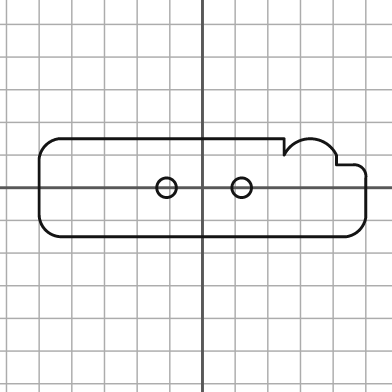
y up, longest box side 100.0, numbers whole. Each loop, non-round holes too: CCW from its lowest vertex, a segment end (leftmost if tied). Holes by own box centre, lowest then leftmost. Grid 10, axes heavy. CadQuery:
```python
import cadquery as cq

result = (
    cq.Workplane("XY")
    .moveTo(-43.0, -15.0)
    .lineTo(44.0, -15.0)
    .threePointArc((48.0, -13.0), (50.0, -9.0))
    .lineTo(50.0, 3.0)
    .threePointArc((49.0, 6.0), (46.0, 7.0))
    .lineTo(41.0, 7.0)
    .lineTo(41.0, 10.0)
    .threePointArc((33.0, 15.0), (25.0, 10.0))
    .lineTo(25.0, 15.0)
    .lineTo(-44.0, 15.0)
    .threePointArc((-48.0, 13.0), (-50.0, 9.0))
    .lineTo(-50.0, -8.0)
    .threePointArc((-48.0, -13.0), (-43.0, -15.0))
    .close()
    .moveTo(-11.0, 0.0)
    .circle(3.0)
    .moveTo(12.0, 0.0)
    .circle(3.0)
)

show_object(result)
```